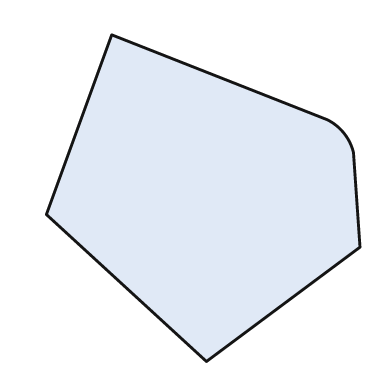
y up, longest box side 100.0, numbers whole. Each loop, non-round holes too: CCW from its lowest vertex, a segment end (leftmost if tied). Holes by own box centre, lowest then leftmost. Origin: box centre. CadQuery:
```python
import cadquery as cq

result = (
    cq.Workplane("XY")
    .moveTo(1.0, -50.0)
    .lineTo(48.0, -15.0)
    .lineTo(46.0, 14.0)
    .threePointArc((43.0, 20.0), (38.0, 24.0))
    .lineTo(-28.0, 50.0)
    .lineTo(-48.0, -5.0)
    .close()
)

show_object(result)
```